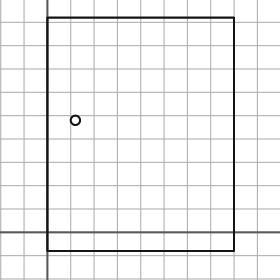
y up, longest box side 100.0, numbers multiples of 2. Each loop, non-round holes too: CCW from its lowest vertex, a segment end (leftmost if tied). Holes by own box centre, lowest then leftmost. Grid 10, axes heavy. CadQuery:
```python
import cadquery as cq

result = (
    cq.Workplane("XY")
    .moveTo(0.0, -8.0)
    .lineTo(80.0, -8.0)
    .lineTo(80.0, 92.0)
    .lineTo(0.0, 92.0)
    .close()
    .moveTo(12.0, 48.0)
    .circle(2.0)
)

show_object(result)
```